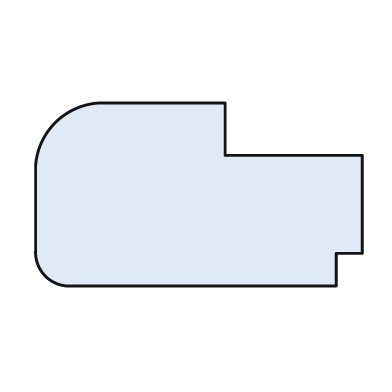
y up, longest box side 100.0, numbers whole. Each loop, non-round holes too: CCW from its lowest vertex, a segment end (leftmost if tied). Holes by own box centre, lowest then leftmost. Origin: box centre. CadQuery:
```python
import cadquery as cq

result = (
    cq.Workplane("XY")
    .moveTo(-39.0, -28.0)
    .lineTo(42.0, -28.0)
    .lineTo(42.0, -18.0)
    .lineTo(50.0, -18.0)
    .lineTo(50.0, 12.0)
    .lineTo(8.0, 12.0)
    .lineTo(8.0, 28.0)
    .lineTo(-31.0, 28.0)
    .threePointArc((-44.0, 22.0), (-50.0, 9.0))
    .lineTo(-50.0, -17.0)
    .threePointArc((-47.0, -25.0), (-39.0, -28.0))
    .close()
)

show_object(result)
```